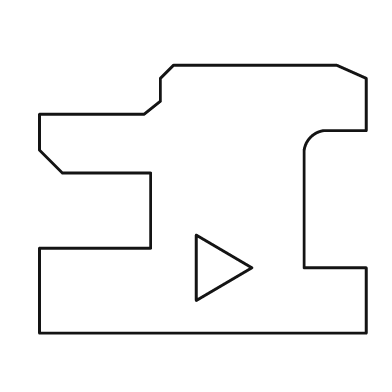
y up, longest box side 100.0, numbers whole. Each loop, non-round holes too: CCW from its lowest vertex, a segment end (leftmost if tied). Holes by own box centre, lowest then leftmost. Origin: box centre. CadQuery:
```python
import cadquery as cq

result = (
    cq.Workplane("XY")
    .moveTo(-50.0, -41.0)
    .lineTo(50.0, -41.0)
    .lineTo(50.0, -21.0)
    .lineTo(31.0, -21.0)
    .lineTo(31.0, 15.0)
    .threePointArc((33.0, 19.0), (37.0, 21.0))
    .lineTo(50.0, 21.0)
    .lineTo(50.0, 37.0)
    .lineTo(41.0, 41.0)
    .lineTo(-9.0, 41.0)
    .lineTo(-13.0, 37.0)
    .lineTo(-13.0, 30.0)
    .lineTo(-18.0, 26.0)
    .lineTo(-50.0, 26.0)
    .lineTo(-50.0, 15.0)
    .lineTo(-43.0, 8.0)
    .lineTo(-16.0, 8.0)
    .lineTo(-16.0, -15.0)
    .lineTo(-50.0, -15.0)
    .close()
    .moveTo(-2.0, -31.0)
    .lineTo(15.0, -21.0)
    .lineTo(-2.0, -11.0)
    .close()
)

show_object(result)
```